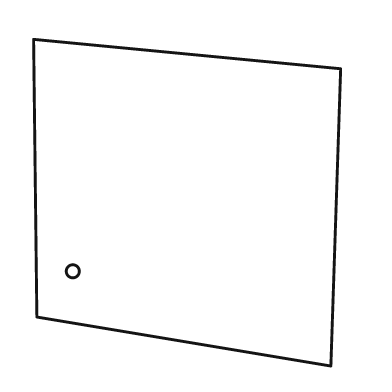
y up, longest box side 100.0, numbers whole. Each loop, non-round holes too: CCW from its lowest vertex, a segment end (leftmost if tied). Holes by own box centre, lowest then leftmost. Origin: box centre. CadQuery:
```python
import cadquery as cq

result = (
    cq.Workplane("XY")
    .moveTo(44.0, -50.0)
    .lineTo(47.0, 41.0)
    .lineTo(-47.0, 50.0)
    .lineTo(-46.0, -35.0)
    .close()
    .moveTo(-35.0, -21.0)
    .circle(2.0)
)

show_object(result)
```